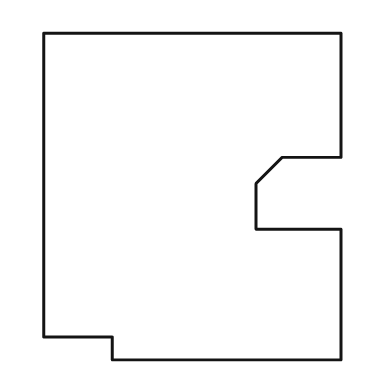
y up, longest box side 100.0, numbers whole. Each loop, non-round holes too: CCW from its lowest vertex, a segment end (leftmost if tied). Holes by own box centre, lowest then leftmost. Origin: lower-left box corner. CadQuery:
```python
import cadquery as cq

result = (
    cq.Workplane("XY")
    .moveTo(21.0, 0.0)
    .lineTo(91.0, 0.0)
    .lineTo(91.0, 40.0)
    .lineTo(65.0, 40.0)
    .lineTo(65.0, 54.0)
    .lineTo(73.0, 62.0)
    .lineTo(91.0, 62.0)
    .lineTo(91.0, 100.0)
    .lineTo(0.0, 100.0)
    .lineTo(0.0, 7.0)
    .lineTo(21.0, 7.0)
    .close()
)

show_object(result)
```